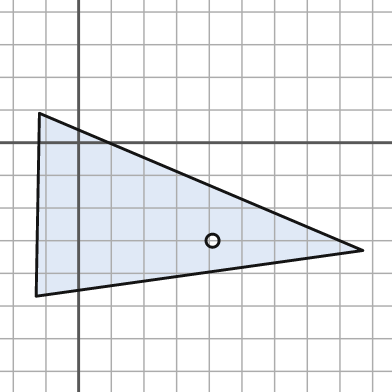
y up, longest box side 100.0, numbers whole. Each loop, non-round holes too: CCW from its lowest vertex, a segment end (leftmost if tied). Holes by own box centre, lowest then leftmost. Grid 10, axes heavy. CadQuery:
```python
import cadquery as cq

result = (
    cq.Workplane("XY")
    .moveTo(-13.0, -47.0)
    .lineTo(87.0, -33.0)
    .lineTo(-12.0, 9.0)
    .close()
    .moveTo(41.0, -30.0)
    .circle(2.0)
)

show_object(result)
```